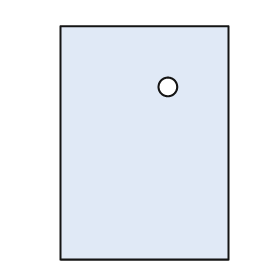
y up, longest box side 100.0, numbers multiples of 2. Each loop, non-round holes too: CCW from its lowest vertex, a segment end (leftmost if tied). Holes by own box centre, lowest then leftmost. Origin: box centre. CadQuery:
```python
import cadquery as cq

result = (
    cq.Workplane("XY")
    .moveTo(-36.0, -50.0)
    .lineTo(36.0, -50.0)
    .lineTo(36.0, 50.0)
    .lineTo(-36.0, 50.0)
    .close()
    .moveTo(10.0, 24.0)
    .circle(4.0)
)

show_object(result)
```